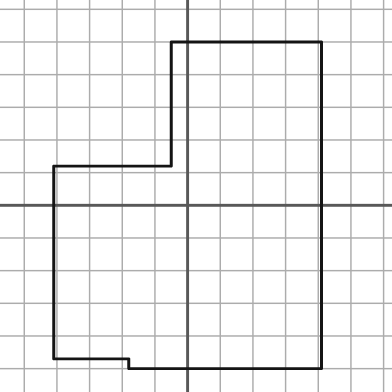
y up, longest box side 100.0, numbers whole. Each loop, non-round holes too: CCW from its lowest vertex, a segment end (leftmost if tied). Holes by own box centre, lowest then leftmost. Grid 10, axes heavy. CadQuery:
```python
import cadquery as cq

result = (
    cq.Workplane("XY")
    .moveTo(-18.0, -50.0)
    .lineTo(41.0, -50.0)
    .lineTo(41.0, 50.0)
    .lineTo(-5.0, 50.0)
    .lineTo(-5.0, 12.0)
    .lineTo(-41.0, 12.0)
    .lineTo(-41.0, -47.0)
    .lineTo(-18.0, -47.0)
    .close()
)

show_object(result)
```